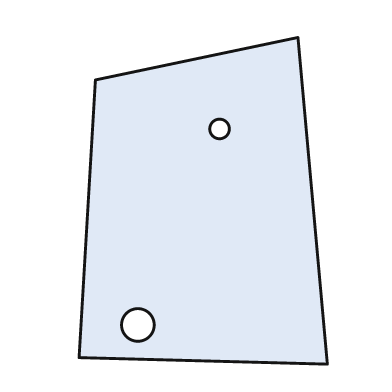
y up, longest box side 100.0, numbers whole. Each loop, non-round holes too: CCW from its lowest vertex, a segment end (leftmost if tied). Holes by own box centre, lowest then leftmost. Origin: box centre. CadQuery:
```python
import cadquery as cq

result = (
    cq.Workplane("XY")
    .moveTo(38.0, -50.0)
    .lineTo(29.0, 50.0)
    .lineTo(-33.0, 37.0)
    .lineTo(-38.0, -48.0)
    .close()
    .moveTo(-20.0, -38.0)
    .circle(5.0)
    .moveTo(5.0, 22.0)
    .circle(3.0)
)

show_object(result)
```